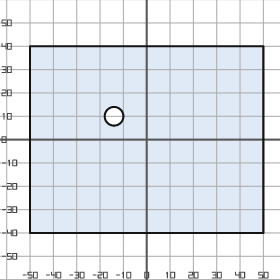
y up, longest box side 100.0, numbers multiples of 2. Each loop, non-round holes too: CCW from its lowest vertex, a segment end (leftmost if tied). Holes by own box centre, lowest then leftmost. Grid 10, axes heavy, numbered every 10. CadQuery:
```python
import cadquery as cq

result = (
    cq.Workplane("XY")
    .moveTo(-50.0, -40.0)
    .lineTo(50.0, -40.0)
    .lineTo(50.0, 40.0)
    .lineTo(-50.0, 40.0)
    .close()
    .moveTo(-14.0, 10.0)
    .circle(4.0)
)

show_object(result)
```